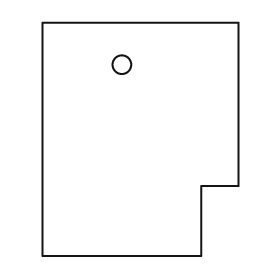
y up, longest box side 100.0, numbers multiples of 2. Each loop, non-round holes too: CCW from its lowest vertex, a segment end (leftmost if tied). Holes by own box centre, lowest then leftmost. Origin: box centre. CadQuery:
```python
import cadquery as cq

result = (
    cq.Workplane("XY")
    .moveTo(-42.0, -50.0)
    .lineTo(26.0, -50.0)
    .lineTo(26.0, -20.0)
    .lineTo(42.0, -20.0)
    .lineTo(42.0, 50.0)
    .lineTo(-42.0, 50.0)
    .close()
    .moveTo(-8.0, 32.0)
    .circle(4.0)
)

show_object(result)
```